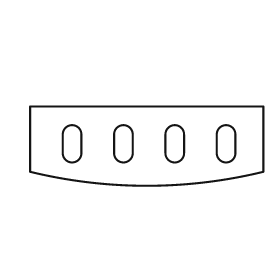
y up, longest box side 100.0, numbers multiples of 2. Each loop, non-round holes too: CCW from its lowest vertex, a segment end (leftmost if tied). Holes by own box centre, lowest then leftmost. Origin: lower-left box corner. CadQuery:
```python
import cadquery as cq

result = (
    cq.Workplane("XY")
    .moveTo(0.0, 6.0)
    .threePointArc((50.0, 0.0), (100.0, 6.0))
    .lineTo(100.0, 34.0)
    .lineTo(0.0, 34.0)
    .close()
    .moveTo(14.0, 14.0)
    .threePointArc((18.0, 10.0), (22.0, 14.0))
    .lineTo(22.0, 22.0)
    .threePointArc((18.0, 26.0), (14.0, 22.0))
    .close()
    .moveTo(36.0, 14.0)
    .threePointArc((40.0, 10.0), (44.0, 14.0))
    .lineTo(44.0, 22.0)
    .threePointArc((40.0, 26.0), (36.0, 22.0))
    .close()
    .moveTo(58.0, 14.0)
    .threePointArc((62.0, 10.0), (66.0, 14.0))
    .lineTo(66.0, 22.0)
    .threePointArc((62.0, 26.0), (58.0, 22.0))
    .close()
    .moveTo(80.0, 14.0)
    .threePointArc((84.0, 10.0), (88.0, 14.0))
    .lineTo(88.0, 22.0)
    .threePointArc((84.0, 26.0), (80.0, 22.0))
    .close()
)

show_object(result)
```